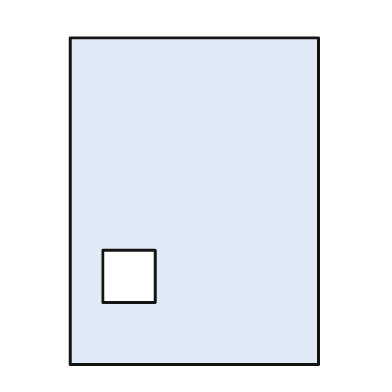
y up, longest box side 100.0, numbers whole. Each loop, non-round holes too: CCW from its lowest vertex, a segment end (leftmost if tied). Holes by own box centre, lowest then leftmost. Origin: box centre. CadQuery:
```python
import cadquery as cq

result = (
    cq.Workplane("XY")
    .moveTo(-38.0, -50.0)
    .lineTo(38.0, -50.0)
    .lineTo(38.0, 50.0)
    .lineTo(-38.0, 50.0)
    .close()
    .moveTo(-28.0, -31.0)
    .lineTo(-12.0, -31.0)
    .lineTo(-12.0, -15.0)
    .lineTo(-28.0, -15.0)
    .close()
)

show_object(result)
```